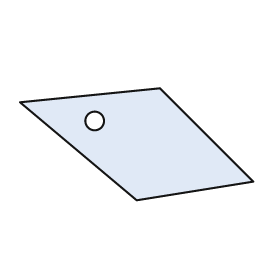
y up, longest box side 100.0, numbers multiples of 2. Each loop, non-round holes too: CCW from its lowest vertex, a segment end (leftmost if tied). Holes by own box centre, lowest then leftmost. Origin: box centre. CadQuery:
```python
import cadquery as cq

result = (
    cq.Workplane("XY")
    .moveTo(0.0, -24.0)
    .lineTo(50.0, -16.0)
    .lineTo(10.0, 24.0)
    .lineTo(-50.0, 18.0)
    .close()
    .moveTo(-18.0, 10.0)
    .circle(4.0)
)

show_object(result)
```